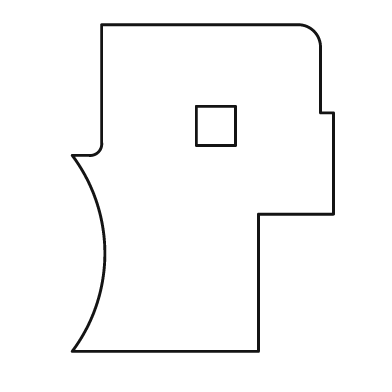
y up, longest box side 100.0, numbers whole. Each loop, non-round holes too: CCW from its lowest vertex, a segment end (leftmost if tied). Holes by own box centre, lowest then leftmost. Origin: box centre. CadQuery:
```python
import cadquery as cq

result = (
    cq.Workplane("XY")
    .moveTo(-40.0, -50.0)
    .lineTo(17.0, -50.0)
    .lineTo(17.0, -8.0)
    .lineTo(40.0, -8.0)
    .lineTo(40.0, 23.0)
    .lineTo(36.0, 23.0)
    .lineTo(36.0, 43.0)
    .threePointArc((34.0, 48.0), (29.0, 50.0))
    .lineTo(-31.0, 50.0)
    .lineTo(-31.0, 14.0)
    .threePointArc((-32.0, 11.0), (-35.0, 10.0))
    .lineTo(-40.0, 10.0)
    .threePointArc((-30.0, -20.0), (-40.0, -50.0))
    .close()
    .moveTo(-2.0, 13.0)
    .lineTo(10.0, 13.0)
    .lineTo(10.0, 25.0)
    .lineTo(-2.0, 25.0)
    .close()
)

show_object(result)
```